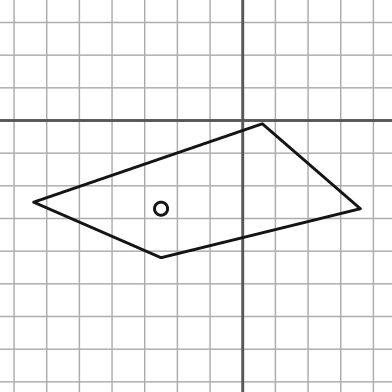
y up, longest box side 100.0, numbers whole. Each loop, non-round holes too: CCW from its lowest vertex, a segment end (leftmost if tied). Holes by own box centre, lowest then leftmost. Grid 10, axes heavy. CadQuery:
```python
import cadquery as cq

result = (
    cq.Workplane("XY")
    .moveTo(-25.0, -42.0)
    .lineTo(36.0, -27.0)
    .lineTo(6.0, -1.0)
    .lineTo(-64.0, -25.0)
    .close()
    .moveTo(-25.0, -27.0)
    .circle(2.0)
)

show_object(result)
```